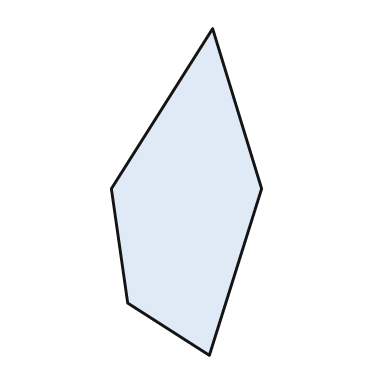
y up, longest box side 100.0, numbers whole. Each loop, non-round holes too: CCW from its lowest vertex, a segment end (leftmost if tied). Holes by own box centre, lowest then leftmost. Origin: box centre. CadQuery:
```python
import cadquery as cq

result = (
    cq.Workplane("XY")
    .moveTo(7.0, -50.0)
    .lineTo(23.0, 1.0)
    .lineTo(8.0, 50.0)
    .lineTo(-23.0, 1.0)
    .lineTo(-18.0, -34.0)
    .close()
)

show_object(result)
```